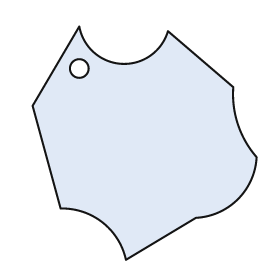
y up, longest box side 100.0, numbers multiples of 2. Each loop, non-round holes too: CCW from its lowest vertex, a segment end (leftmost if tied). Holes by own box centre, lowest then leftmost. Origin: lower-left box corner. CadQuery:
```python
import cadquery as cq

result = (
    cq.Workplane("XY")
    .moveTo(40.0, 0.0)
    .lineTo(70.0, 18.0)
    .threePointArc((88.0, 26.0), (96.0, 44.0))
    .threePointArc((88.0, 58.0), (86.0, 74.0))
    .lineTo(58.0, 98.0)
    .threePointArc((38.0, 84.0), (20.0, 100.0))
    .lineTo(0.0, 66.0)
    .lineTo(12.0, 22.0)
    .threePointArc((30.0, 16.0), (40.0, 0.0))
    .close()
    .moveTo(20.0, 82.0)
    .circle(4.0)
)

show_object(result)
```